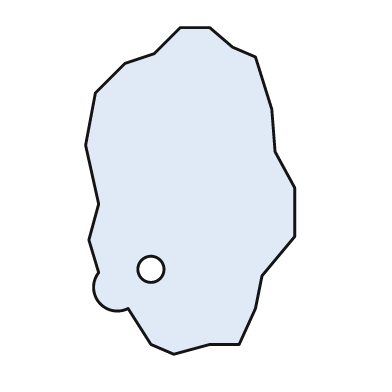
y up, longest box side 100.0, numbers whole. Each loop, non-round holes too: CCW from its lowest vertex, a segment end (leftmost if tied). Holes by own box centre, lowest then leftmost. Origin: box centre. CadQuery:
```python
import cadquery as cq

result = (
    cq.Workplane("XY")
    .moveTo(-5.0, -50.0)
    .lineTo(6.0, -47.0)
    .lineTo(15.0, -47.0)
    .lineTo(20.0, -36.0)
    .lineTo(22.0, -26.0)
    .lineTo(32.0, -14.0)
    .lineTo(32.0, 1.0)
    .lineTo(26.0, 12.0)
    .lineTo(25.0, 25.0)
    .lineTo(20.0, 41.0)
    .lineTo(13.0, 44.0)
    .lineTo(6.0, 50.0)
    .lineTo(-3.0, 50.0)
    .lineTo(-11.0, 42.0)
    .lineTo(-20.0, 39.0)
    .lineTo(-29.0, 30.0)
    .lineTo(-32.0, 14.0)
    .lineTo(-28.0, -4.0)
    .lineTo(-31.0, -15.0)
    .lineTo(-28.0, -25.0)
    .threePointArc((-28.0, -34.0), (-19.0, -36.0))
    .lineTo(-12.0, -47.0)
    .close()
    .moveTo(-12.0, -24.0)
    .circle(4.0)
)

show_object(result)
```